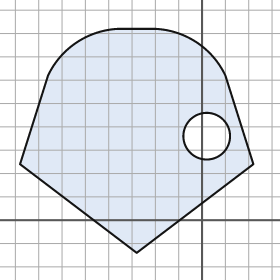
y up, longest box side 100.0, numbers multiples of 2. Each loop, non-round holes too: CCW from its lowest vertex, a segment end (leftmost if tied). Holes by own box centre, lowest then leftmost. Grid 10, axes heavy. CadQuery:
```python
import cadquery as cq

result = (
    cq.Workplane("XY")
    .moveTo(-28.0, -14.0)
    .lineTo(22.0, 24.0)
    .lineTo(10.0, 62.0)
    .threePointArc((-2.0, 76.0), (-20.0, 82.0))
    .lineTo(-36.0, 82.0)
    .threePointArc((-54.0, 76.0), (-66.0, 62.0))
    .lineTo(-78.0, 24.0)
    .close()
    .moveTo(2.0, 36.0)
    .circle(10.0)
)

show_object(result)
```